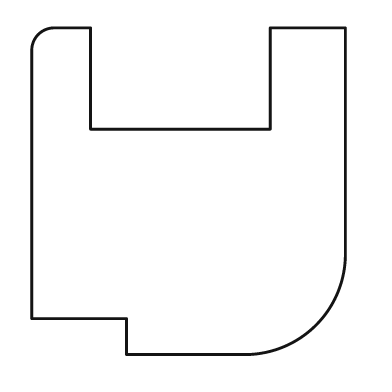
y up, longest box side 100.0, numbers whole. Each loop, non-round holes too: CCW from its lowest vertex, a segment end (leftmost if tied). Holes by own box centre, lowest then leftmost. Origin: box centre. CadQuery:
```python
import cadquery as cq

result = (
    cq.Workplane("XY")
    .moveTo(-19.0, -50.0)
    .lineTo(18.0, -50.0)
    .threePointArc((39.0, -41.0), (48.0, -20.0))
    .lineTo(48.0, 50.0)
    .lineTo(25.0, 50.0)
    .lineTo(25.0, 19.0)
    .lineTo(-30.0, 19.0)
    .lineTo(-30.0, 50.0)
    .lineTo(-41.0, 50.0)
    .threePointArc((-46.0, 48.0), (-48.0, 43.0))
    .lineTo(-48.0, -39.0)
    .lineTo(-19.0, -39.0)
    .close()
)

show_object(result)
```